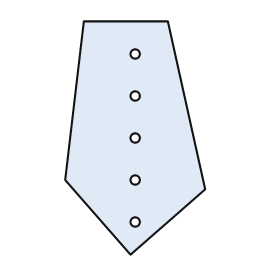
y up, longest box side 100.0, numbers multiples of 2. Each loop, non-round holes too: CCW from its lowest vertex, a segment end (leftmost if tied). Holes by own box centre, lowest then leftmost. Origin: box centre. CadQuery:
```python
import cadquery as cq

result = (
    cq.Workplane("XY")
    .moveTo(-2.0, -50.0)
    .lineTo(30.0, -22.0)
    .lineTo(14.0, 50.0)
    .lineTo(-22.0, 50.0)
    .lineTo(-30.0, -18.0)
    .close()
    .moveTo(0.0, -36.0)
    .circle(2.0)
    .moveTo(0.0, -18.0)
    .circle(2.0)
    .moveTo(0.0, 0.0)
    .circle(2.0)
    .moveTo(0.0, 18.0)
    .circle(2.0)
    .moveTo(0.0, 36.0)
    .circle(2.0)
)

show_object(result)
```